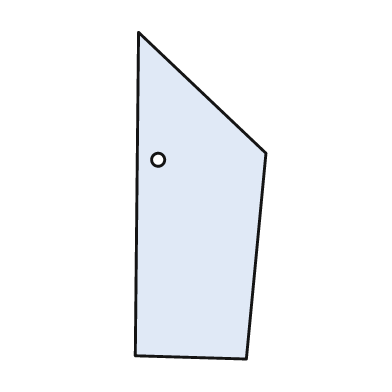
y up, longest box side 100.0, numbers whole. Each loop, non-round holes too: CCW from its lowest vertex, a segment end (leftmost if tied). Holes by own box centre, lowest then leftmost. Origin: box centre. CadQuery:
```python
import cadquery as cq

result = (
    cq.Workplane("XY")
    .moveTo(14.0, -50.0)
    .lineTo(20.0, 13.0)
    .lineTo(-19.0, 50.0)
    .lineTo(-20.0, -49.0)
    .close()
    .moveTo(-13.0, 11.0)
    .circle(2.0)
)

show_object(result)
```